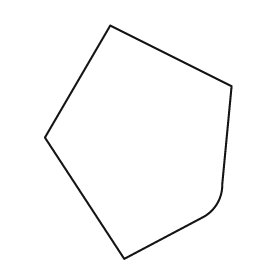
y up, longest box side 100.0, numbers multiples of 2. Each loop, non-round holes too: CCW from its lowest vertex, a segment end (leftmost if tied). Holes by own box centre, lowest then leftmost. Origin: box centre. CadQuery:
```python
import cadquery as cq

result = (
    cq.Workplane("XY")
    .moveTo(-6.0, -50.0)
    .lineTo(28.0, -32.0)
    .threePointArc((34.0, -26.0), (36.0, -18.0))
    .lineTo(40.0, 24.0)
    .lineTo(-12.0, 50.0)
    .lineTo(-40.0, 2.0)
    .close()
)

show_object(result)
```